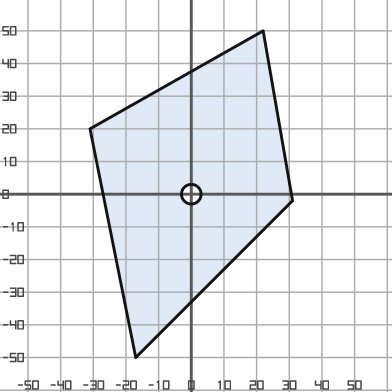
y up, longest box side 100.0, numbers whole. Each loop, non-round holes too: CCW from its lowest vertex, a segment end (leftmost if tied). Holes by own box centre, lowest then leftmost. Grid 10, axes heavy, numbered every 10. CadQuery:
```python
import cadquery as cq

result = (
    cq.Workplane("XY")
    .moveTo(-17.0, -50.0)
    .lineTo(31.0, -2.0)
    .lineTo(22.0, 50.0)
    .lineTo(-31.0, 20.0)
    .close()
    .moveTo(0.0, 0.0)
    .circle(3.0)
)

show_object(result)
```